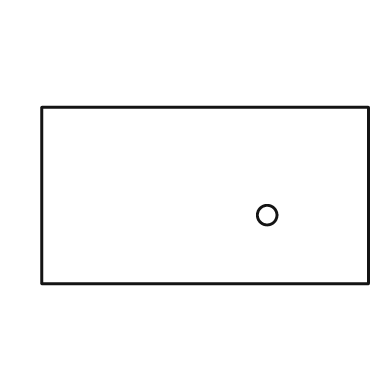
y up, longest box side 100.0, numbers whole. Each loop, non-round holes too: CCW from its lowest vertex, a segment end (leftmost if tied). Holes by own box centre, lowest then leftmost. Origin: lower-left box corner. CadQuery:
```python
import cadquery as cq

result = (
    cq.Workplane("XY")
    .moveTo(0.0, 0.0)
    .lineTo(100.0, 0.0)
    .lineTo(100.0, 54.0)
    .lineTo(0.0, 54.0)
    .close()
    .moveTo(69.0, 21.0)
    .circle(3.0)
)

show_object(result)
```